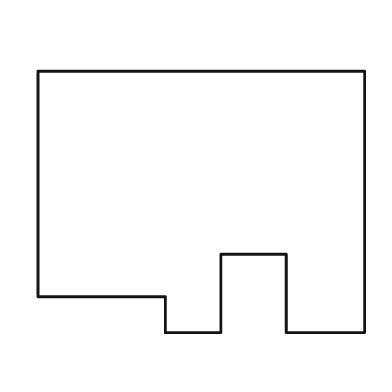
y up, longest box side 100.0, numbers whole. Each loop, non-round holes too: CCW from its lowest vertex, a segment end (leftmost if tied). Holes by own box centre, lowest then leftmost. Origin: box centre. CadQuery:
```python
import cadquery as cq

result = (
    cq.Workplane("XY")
    .moveTo(-11.0, -40.0)
    .lineTo(6.0, -40.0)
    .lineTo(6.0, -16.0)
    .lineTo(26.0, -16.0)
    .lineTo(26.0, -40.0)
    .lineTo(50.0, -40.0)
    .lineTo(50.0, 40.0)
    .lineTo(-50.0, 40.0)
    .lineTo(-50.0, -29.0)
    .lineTo(-11.0, -29.0)
    .close()
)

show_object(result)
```